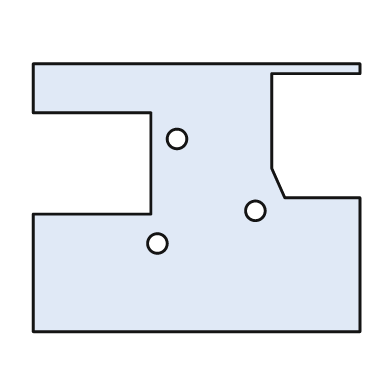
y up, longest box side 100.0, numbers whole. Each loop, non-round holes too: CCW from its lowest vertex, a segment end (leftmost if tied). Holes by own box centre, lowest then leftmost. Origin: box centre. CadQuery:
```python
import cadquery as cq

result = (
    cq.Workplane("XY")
    .moveTo(-50.0, -41.0)
    .lineTo(50.0, -41.0)
    .lineTo(50.0, 0.0)
    .lineTo(27.0, 0.0)
    .lineTo(23.0, 9.0)
    .lineTo(23.0, 38.0)
    .lineTo(50.0, 38.0)
    .lineTo(50.0, 41.0)
    .lineTo(-50.0, 41.0)
    .lineTo(-50.0, 26.0)
    .lineTo(-14.0, 26.0)
    .lineTo(-14.0, -5.0)
    .lineTo(-50.0, -5.0)
    .close()
    .moveTo(-12.0, -14.0)
    .circle(3.0)
    .moveTo(18.0, -4.0)
    .circle(3.0)
    .moveTo(-6.0, 18.0)
    .circle(3.0)
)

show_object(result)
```